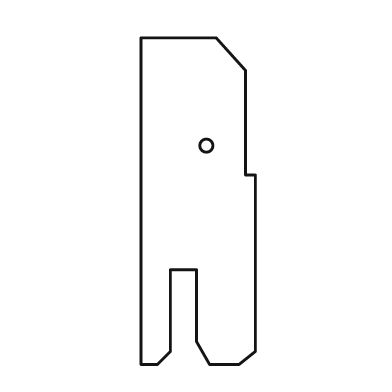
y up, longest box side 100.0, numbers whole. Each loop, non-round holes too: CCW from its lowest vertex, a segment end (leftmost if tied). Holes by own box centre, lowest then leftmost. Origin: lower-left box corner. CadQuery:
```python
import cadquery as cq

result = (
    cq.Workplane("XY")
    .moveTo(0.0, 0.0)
    .lineTo(5.0, 0.0)
    .lineTo(9.0, 4.0)
    .lineTo(9.0, 29.0)
    .lineTo(17.0, 29.0)
    .lineTo(17.0, 7.0)
    .lineTo(21.0, 0.0)
    .lineTo(30.0, 0.0)
    .lineTo(35.0, 4.0)
    .lineTo(35.0, 58.0)
    .lineTo(32.0, 58.0)
    .lineTo(32.0, 90.0)
    .lineTo(23.0, 100.0)
    .lineTo(0.0, 100.0)
    .close()
    .moveTo(20.0, 67.0)
    .circle(2.0)
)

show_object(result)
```